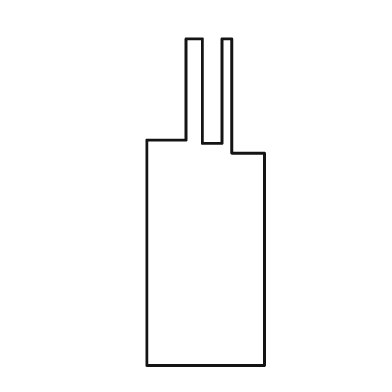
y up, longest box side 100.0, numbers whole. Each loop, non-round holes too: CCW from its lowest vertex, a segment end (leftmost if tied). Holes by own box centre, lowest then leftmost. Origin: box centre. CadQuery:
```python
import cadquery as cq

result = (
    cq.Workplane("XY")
    .moveTo(-18.0, -50.0)
    .lineTo(18.0, -50.0)
    .lineTo(18.0, 15.0)
    .lineTo(8.0, 15.0)
    .lineTo(8.0, 50.0)
    .lineTo(5.0, 50.0)
    .lineTo(5.0, 18.0)
    .lineTo(-1.0, 18.0)
    .lineTo(-1.0, 50.0)
    .lineTo(-6.0, 50.0)
    .lineTo(-6.0, 19.0)
    .lineTo(-18.0, 19.0)
    .close()
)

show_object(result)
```